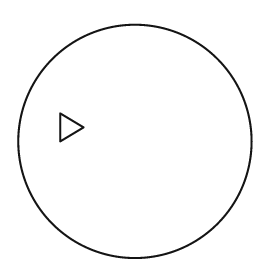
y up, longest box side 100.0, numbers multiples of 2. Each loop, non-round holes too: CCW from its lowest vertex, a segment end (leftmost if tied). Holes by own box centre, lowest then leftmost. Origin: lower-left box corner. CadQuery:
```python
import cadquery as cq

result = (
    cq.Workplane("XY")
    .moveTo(50.0, 50.0)
    .circle(50.0)
    .moveTo(18.0, 50.0)
    .lineTo(28.0, 56.0)
    .lineTo(18.0, 62.0)
    .close()
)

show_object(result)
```